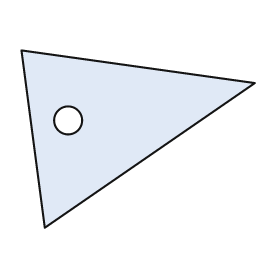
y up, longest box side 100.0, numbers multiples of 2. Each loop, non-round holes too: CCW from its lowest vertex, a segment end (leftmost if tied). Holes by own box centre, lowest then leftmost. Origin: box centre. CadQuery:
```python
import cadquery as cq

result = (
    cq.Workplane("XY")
    .moveTo(-40.0, -38.0)
    .lineTo(50.0, 24.0)
    .lineTo(-50.0, 38.0)
    .close()
    .moveTo(-30.0, 8.0)
    .circle(6.0)
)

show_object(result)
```